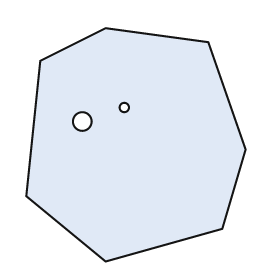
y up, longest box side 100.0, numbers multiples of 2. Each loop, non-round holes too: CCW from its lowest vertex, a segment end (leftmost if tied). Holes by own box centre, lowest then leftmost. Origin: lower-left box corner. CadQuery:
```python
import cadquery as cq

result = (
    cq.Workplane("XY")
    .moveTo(34.0, 0.0)
    .lineTo(84.0, 14.0)
    .lineTo(94.0, 48.0)
    .lineTo(78.0, 94.0)
    .lineTo(34.0, 100.0)
    .lineTo(6.0, 86.0)
    .lineTo(0.0, 28.0)
    .close()
    .moveTo(24.0, 60.0)
    .circle(4.0)
    .moveTo(42.0, 66.0)
    .circle(2.0)
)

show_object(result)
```